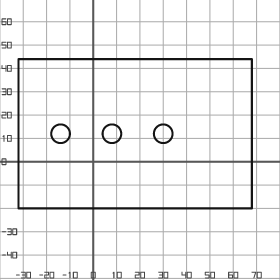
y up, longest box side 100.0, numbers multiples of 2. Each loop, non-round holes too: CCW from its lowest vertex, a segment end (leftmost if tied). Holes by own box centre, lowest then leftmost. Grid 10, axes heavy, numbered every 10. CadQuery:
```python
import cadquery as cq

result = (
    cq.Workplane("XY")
    .moveTo(-32.0, -20.0)
    .lineTo(68.0, -20.0)
    .lineTo(68.0, 44.0)
    .lineTo(-32.0, 44.0)
    .close()
    .moveTo(-14.0, 12.0)
    .circle(4.0)
    .moveTo(8.0, 12.0)
    .circle(4.0)
    .moveTo(30.0, 12.0)
    .circle(4.0)
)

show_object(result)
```